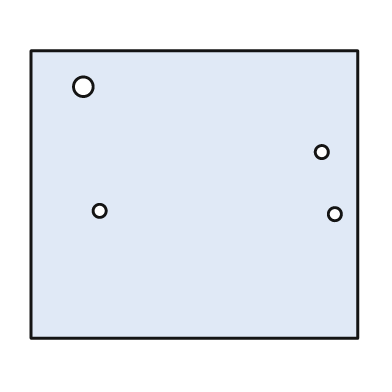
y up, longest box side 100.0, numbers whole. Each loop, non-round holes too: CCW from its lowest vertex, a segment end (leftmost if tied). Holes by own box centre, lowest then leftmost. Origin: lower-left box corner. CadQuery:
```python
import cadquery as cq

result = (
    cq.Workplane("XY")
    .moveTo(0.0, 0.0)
    .lineTo(100.0, 0.0)
    .lineTo(100.0, 88.0)
    .lineTo(0.0, 88.0)
    .close()
    .moveTo(93.0, 38.0)
    .circle(2.0)
    .moveTo(21.0, 39.0)
    .circle(2.0)
    .moveTo(89.0, 57.0)
    .circle(2.0)
    .moveTo(16.0, 77.0)
    .circle(3.0)
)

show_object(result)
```